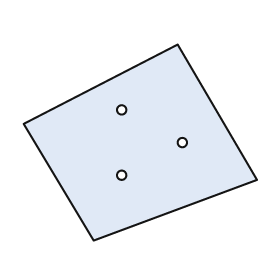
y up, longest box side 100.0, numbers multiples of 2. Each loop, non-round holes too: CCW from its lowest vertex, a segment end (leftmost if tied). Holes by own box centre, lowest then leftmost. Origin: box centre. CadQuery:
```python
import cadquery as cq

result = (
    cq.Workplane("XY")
    .moveTo(-20.0, -42.0)
    .lineTo(50.0, -16.0)
    .lineTo(16.0, 42.0)
    .lineTo(-50.0, 8.0)
    .close()
    .moveTo(-8.0, -14.0)
    .circle(2.0)
    .moveTo(18.0, 0.0)
    .circle(2.0)
    .moveTo(-8.0, 14.0)
    .circle(2.0)
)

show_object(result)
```